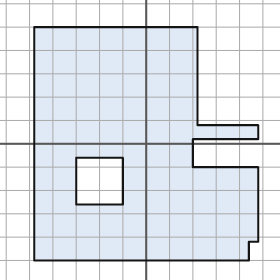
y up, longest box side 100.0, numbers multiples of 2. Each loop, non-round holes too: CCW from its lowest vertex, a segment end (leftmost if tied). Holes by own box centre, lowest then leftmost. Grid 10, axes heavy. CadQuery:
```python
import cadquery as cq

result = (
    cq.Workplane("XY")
    .moveTo(-48.0, -50.0)
    .lineTo(44.0, -50.0)
    .lineTo(44.0, -42.0)
    .lineTo(48.0, -42.0)
    .lineTo(48.0, -10.0)
    .lineTo(20.0, -10.0)
    .lineTo(20.0, 2.0)
    .lineTo(48.0, 2.0)
    .lineTo(48.0, 8.0)
    .lineTo(22.0, 8.0)
    .lineTo(22.0, 50.0)
    .lineTo(-48.0, 50.0)
    .close()
    .moveTo(-30.0, -26.0)
    .lineTo(-10.0, -26.0)
    .lineTo(-10.0, -6.0)
    .lineTo(-30.0, -6.0)
    .close()
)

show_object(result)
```